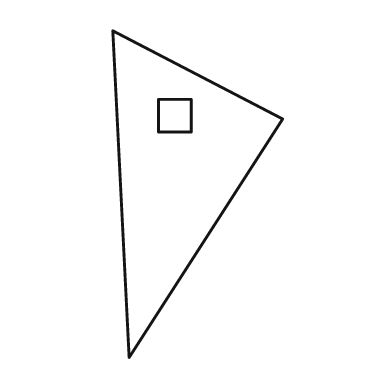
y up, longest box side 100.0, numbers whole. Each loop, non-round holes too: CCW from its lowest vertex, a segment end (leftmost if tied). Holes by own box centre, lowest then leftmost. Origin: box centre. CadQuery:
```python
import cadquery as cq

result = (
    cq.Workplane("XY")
    .moveTo(-21.0, -50.0)
    .lineTo(26.0, 23.0)
    .lineTo(-26.0, 50.0)
    .close()
    .moveTo(-12.0, 19.0)
    .lineTo(-2.0, 19.0)
    .lineTo(-2.0, 29.0)
    .lineTo(-12.0, 29.0)
    .close()
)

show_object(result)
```